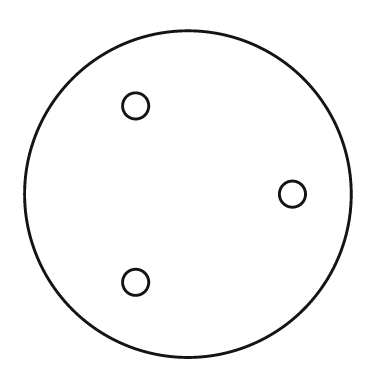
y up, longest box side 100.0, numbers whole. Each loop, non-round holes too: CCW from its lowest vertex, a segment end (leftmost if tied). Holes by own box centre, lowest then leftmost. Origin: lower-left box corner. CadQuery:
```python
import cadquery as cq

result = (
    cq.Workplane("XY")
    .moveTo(50.0, 50.0)
    .circle(50.0)
    .moveTo(34.0, 23.0)
    .circle(4.0)
    .moveTo(82.0, 50.0)
    .circle(4.0)
    .moveTo(34.0, 77.0)
    .circle(4.0)
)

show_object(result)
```